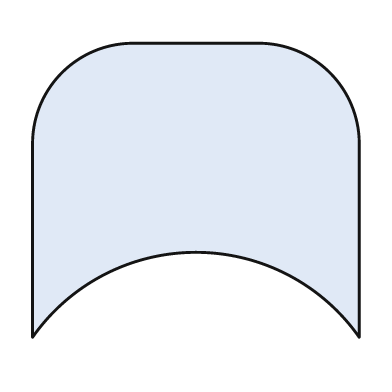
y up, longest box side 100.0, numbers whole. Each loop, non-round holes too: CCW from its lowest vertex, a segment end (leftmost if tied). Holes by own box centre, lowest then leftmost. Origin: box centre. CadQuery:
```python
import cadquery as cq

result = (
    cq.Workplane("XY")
    .moveTo(-50.0, -45.0)
    .threePointArc((0.0, -19.0), (50.0, -45.0))
    .lineTo(50.0, 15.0)
    .threePointArc((41.0, 36.0), (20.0, 45.0))
    .lineTo(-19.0, 45.0)
    .threePointArc((-41.0, 36.0), (-50.0, 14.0))
    .close()
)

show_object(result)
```